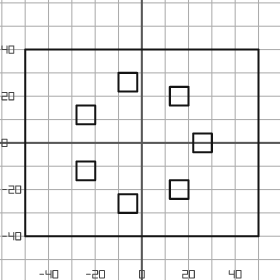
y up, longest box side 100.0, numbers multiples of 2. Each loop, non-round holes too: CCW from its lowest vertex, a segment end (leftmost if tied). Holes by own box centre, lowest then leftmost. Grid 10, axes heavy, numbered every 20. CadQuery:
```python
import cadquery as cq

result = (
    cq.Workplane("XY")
    .moveTo(-50.0, -40.0)
    .lineTo(50.0, -40.0)
    .lineTo(50.0, 40.0)
    .lineTo(-50.0, 40.0)
    .close()
    .moveTo(-10.0, -30.0)
    .lineTo(-2.0, -30.0)
    .lineTo(-2.0, -22.0)
    .lineTo(-10.0, -22.0)
    .close()
    .moveTo(12.0, -24.0)
    .lineTo(20.0, -24.0)
    .lineTo(20.0, -16.0)
    .lineTo(12.0, -16.0)
    .close()
    .moveTo(-28.0, -16.0)
    .lineTo(-20.0, -16.0)
    .lineTo(-20.0, -8.0)
    .lineTo(-28.0, -8.0)
    .close()
    .moveTo(22.0, -4.0)
    .lineTo(30.0, -4.0)
    .lineTo(30.0, 4.0)
    .lineTo(22.0, 4.0)
    .close()
    .moveTo(-28.0, 8.0)
    .lineTo(-20.0, 8.0)
    .lineTo(-20.0, 16.0)
    .lineTo(-28.0, 16.0)
    .close()
    .moveTo(12.0, 16.0)
    .lineTo(20.0, 16.0)
    .lineTo(20.0, 24.0)
    .lineTo(12.0, 24.0)
    .close()
    .moveTo(-10.0, 22.0)
    .lineTo(-2.0, 22.0)
    .lineTo(-2.0, 30.0)
    .lineTo(-10.0, 30.0)
    .close()
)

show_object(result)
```